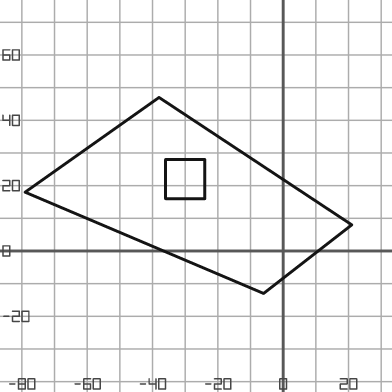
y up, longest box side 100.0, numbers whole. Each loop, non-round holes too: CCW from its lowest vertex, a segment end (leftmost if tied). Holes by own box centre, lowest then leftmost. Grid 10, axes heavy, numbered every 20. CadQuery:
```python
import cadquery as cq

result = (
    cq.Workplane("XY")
    .moveTo(-6.0, -13.0)
    .lineTo(21.0, 8.0)
    .lineTo(-38.0, 47.0)
    .lineTo(-79.0, 18.0)
    .close()
    .moveTo(-36.0, 16.0)
    .lineTo(-24.0, 16.0)
    .lineTo(-24.0, 28.0)
    .lineTo(-36.0, 28.0)
    .close()
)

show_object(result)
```